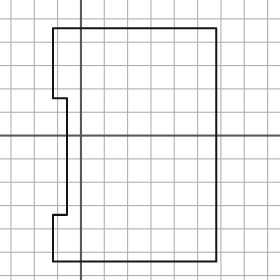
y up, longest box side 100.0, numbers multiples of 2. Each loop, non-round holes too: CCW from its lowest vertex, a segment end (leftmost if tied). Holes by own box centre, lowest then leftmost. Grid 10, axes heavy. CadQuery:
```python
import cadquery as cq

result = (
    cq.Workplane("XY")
    .moveTo(-12.0, -54.0)
    .lineTo(58.0, -54.0)
    .lineTo(58.0, 46.0)
    .lineTo(-12.0, 46.0)
    .lineTo(-12.0, 16.0)
    .lineTo(-6.0, 16.0)
    .lineTo(-6.0, -34.0)
    .lineTo(-12.0, -34.0)
    .close()
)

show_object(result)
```